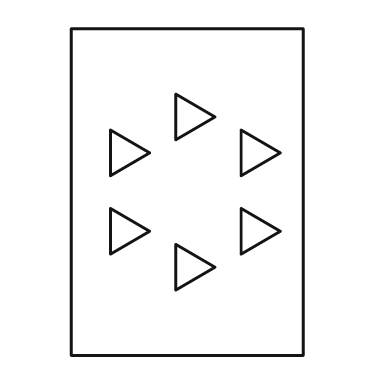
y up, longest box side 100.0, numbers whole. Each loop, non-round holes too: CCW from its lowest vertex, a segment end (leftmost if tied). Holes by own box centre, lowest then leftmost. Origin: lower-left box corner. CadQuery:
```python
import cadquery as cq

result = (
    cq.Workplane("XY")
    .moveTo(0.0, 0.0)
    .lineTo(71.0, 0.0)
    .lineTo(71.0, 100.0)
    .lineTo(0.0, 100.0)
    .close()
    .moveTo(32.0, 20.0)
    .lineTo(44.0, 27.0)
    .lineTo(32.0, 34.0)
    .close()
    .moveTo(12.0, 31.0)
    .lineTo(24.0, 38.0)
    .lineTo(12.0, 45.0)
    .close()
    .moveTo(52.0, 31.0)
    .lineTo(64.0, 38.0)
    .lineTo(52.0, 45.0)
    .close()
    .moveTo(12.0, 55.0)
    .lineTo(24.0, 62.0)
    .lineTo(12.0, 69.0)
    .close()
    .moveTo(52.0, 55.0)
    .lineTo(64.0, 62.0)
    .lineTo(52.0, 69.0)
    .close()
    .moveTo(32.0, 66.0)
    .lineTo(44.0, 73.0)
    .lineTo(32.0, 80.0)
    .close()
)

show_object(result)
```